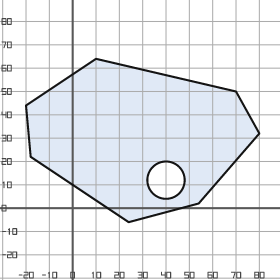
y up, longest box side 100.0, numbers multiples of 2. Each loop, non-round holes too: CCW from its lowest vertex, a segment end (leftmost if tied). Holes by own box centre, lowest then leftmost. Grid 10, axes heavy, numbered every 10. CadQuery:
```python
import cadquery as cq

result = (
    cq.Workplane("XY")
    .moveTo(24.0, -6.0)
    .lineTo(54.0, 2.0)
    .lineTo(80.0, 32.0)
    .lineTo(70.0, 50.0)
    .lineTo(10.0, 64.0)
    .lineTo(-20.0, 44.0)
    .lineTo(-18.0, 22.0)
    .close()
    .moveTo(40.0, 12.0)
    .circle(8.0)
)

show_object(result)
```